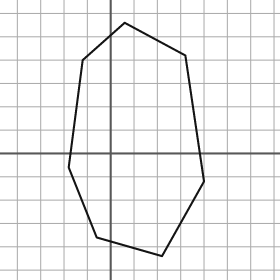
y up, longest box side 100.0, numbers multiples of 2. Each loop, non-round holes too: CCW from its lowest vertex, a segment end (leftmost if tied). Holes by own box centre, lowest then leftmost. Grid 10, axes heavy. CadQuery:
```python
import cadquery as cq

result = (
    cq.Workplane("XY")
    .moveTo(22.0, -44.0)
    .lineTo(40.0, -12.0)
    .lineTo(32.0, 42.0)
    .lineTo(6.0, 56.0)
    .lineTo(-12.0, 40.0)
    .lineTo(-18.0, -6.0)
    .lineTo(-6.0, -36.0)
    .close()
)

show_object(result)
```